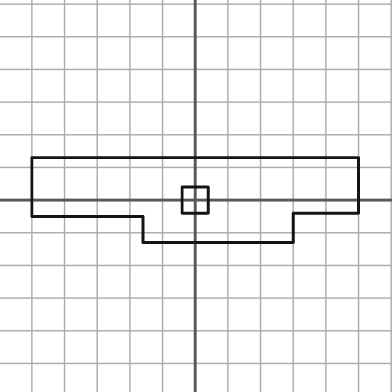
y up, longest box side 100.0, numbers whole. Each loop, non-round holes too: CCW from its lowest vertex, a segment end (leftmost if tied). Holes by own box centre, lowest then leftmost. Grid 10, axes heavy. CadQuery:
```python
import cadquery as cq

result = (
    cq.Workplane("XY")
    .moveTo(-16.0, -13.0)
    .lineTo(30.0, -13.0)
    .lineTo(30.0, -4.0)
    .lineTo(50.0, -4.0)
    .lineTo(50.0, 13.0)
    .lineTo(-50.0, 13.0)
    .lineTo(-50.0, -5.0)
    .lineTo(-16.0, -5.0)
    .close()
    .moveTo(-4.0, -4.0)
    .lineTo(4.0, -4.0)
    .lineTo(4.0, 4.0)
    .lineTo(-4.0, 4.0)
    .close()
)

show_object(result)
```